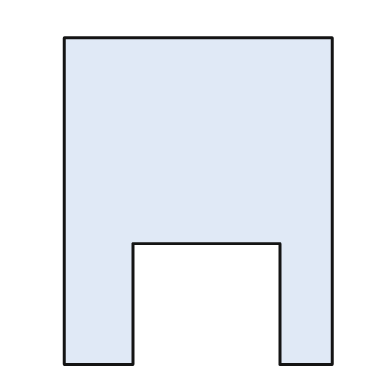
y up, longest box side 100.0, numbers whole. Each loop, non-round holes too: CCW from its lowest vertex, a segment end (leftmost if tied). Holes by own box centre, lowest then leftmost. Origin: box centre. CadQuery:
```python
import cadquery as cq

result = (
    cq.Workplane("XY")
    .moveTo(-41.0, -50.0)
    .lineTo(-20.0, -50.0)
    .lineTo(-20.0, -13.0)
    .lineTo(25.0, -13.0)
    .lineTo(25.0, -50.0)
    .lineTo(41.0, -50.0)
    .lineTo(41.0, 50.0)
    .lineTo(-41.0, 50.0)
    .close()
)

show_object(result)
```